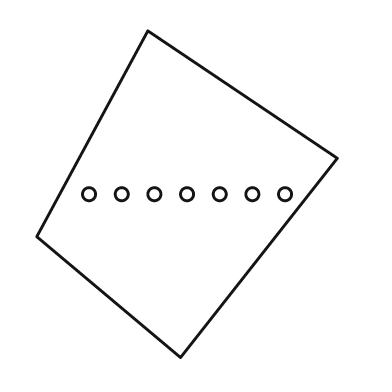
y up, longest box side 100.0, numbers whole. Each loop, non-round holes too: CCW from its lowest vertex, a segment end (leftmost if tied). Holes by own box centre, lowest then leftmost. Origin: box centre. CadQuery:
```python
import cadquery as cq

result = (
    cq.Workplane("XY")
    .moveTo(-2.0, -50.0)
    .lineTo(46.0, 11.0)
    .lineTo(-12.0, 50.0)
    .lineTo(-46.0, -13.0)
    .close()
    .moveTo(-30.0, 0.0)
    .circle(2.0)
    .moveTo(-20.0, 0.0)
    .circle(2.0)
    .moveTo(-10.0, 0.0)
    .circle(2.0)
    .moveTo(0.0, 0.0)
    .circle(2.0)
    .moveTo(10.0, 0.0)
    .circle(2.0)
    .moveTo(20.0, 0.0)
    .circle(2.0)
    .moveTo(30.0, 0.0)
    .circle(2.0)
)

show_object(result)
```